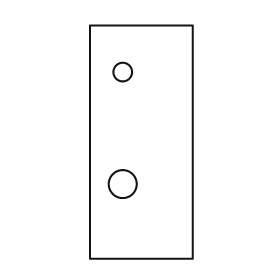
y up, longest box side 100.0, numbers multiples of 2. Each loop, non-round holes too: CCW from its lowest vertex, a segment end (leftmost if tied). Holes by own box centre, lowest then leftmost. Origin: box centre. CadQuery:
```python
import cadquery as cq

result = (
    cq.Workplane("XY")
    .moveTo(-22.0, -50.0)
    .lineTo(22.0, -50.0)
    .lineTo(22.0, 50.0)
    .lineTo(-22.0, 50.0)
    .close()
    .moveTo(-8.0, -18.0)
    .circle(6.0)
    .moveTo(-8.0, 30.0)
    .circle(4.0)
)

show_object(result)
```